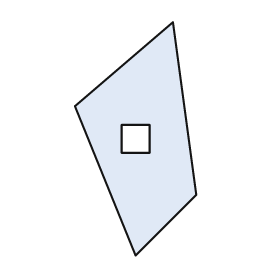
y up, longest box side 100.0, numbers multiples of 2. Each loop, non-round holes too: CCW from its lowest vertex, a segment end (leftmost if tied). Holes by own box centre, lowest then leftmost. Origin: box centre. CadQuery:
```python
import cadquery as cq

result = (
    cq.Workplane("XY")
    .moveTo(0.0, -50.0)
    .lineTo(26.0, -24.0)
    .lineTo(16.0, 50.0)
    .lineTo(-26.0, 14.0)
    .close()
    .moveTo(-6.0, -6.0)
    .lineTo(6.0, -6.0)
    .lineTo(6.0, 6.0)
    .lineTo(-6.0, 6.0)
    .close()
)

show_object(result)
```